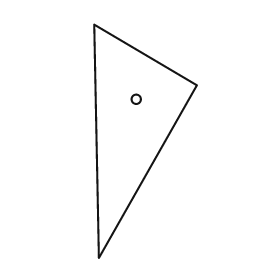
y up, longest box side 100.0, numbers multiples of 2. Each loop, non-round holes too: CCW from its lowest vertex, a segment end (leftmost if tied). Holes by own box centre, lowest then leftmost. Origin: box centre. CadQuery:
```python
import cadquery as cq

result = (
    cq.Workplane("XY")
    .moveTo(-20.0, -50.0)
    .lineTo(22.0, 24.0)
    .lineTo(-22.0, 50.0)
    .close()
    .moveTo(-4.0, 18.0)
    .circle(2.0)
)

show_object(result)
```